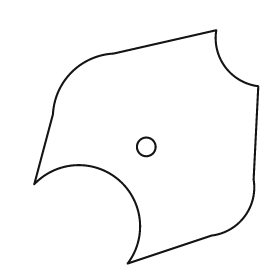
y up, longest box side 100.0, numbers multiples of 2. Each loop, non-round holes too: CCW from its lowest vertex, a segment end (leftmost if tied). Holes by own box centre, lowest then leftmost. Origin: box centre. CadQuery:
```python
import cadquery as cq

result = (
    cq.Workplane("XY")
    .moveTo(-8.0, -50.0)
    .lineTo(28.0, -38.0)
    .threePointArc((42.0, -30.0), (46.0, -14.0))
    .lineTo(48.0, 26.0)
    .threePointArc((34.0, 34.0), (30.0, 50.0))
    .lineTo(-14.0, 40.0)
    .threePointArc((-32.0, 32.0), (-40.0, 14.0))
    .lineTo(-48.0, -16.0)
    .threePointArc((-12.0, -14.0), (-8.0, -50.0))
    .close()
    .moveTo(0.0, 0.0)
    .circle(4.0)
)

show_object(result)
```